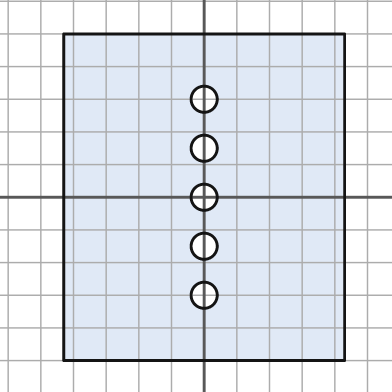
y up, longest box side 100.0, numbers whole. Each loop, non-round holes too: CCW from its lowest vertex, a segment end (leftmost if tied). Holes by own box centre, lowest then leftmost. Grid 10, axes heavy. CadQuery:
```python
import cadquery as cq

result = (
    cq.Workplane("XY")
    .moveTo(-43.0, -50.0)
    .lineTo(43.0, -50.0)
    .lineTo(43.0, 50.0)
    .lineTo(-43.0, 50.0)
    .close()
    .moveTo(0.0, -30.0)
    .circle(4.0)
    .moveTo(0.0, -15.0)
    .circle(4.0)
    .moveTo(0.0, 0.0)
    .circle(4.0)
    .moveTo(0.0, 15.0)
    .circle(4.0)
    .moveTo(0.0, 30.0)
    .circle(4.0)
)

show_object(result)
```